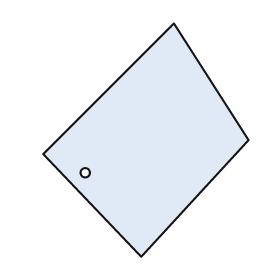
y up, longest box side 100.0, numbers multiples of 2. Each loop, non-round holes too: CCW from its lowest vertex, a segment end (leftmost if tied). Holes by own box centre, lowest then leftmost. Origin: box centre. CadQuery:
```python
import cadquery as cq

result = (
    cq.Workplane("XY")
    .moveTo(-2.0, -50.0)
    .lineTo(44.0, 0.0)
    .lineTo(12.0, 50.0)
    .lineTo(-44.0, -6.0)
    .close()
    .moveTo(-26.0, -14.0)
    .circle(2.0)
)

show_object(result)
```